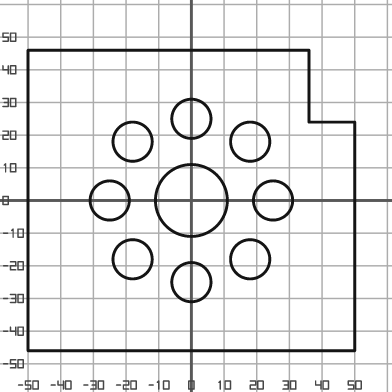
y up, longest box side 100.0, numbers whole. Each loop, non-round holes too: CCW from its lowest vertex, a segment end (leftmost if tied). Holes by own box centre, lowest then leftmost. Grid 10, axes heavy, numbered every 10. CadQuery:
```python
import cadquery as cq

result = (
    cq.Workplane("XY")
    .moveTo(-50.0, -46.0)
    .lineTo(50.0, -46.0)
    .lineTo(50.0, 24.0)
    .lineTo(36.0, 24.0)
    .lineTo(36.0, 46.0)
    .lineTo(-50.0, 46.0)
    .close()
    .moveTo(0.0, -25.0)
    .circle(6.0)
    .moveTo(-18.0, -18.0)
    .circle(6.0)
    .moveTo(18.0, -18.0)
    .circle(6.0)
    .moveTo(-25.0, 0.0)
    .circle(6.0)
    .moveTo(0.0, 0.0)
    .circle(11.0)
    .moveTo(25.0, 0.0)
    .circle(6.0)
    .moveTo(-18.0, 18.0)
    .circle(6.0)
    .moveTo(18.0, 18.0)
    .circle(6.0)
    .moveTo(0.0, 25.0)
    .circle(6.0)
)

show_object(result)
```